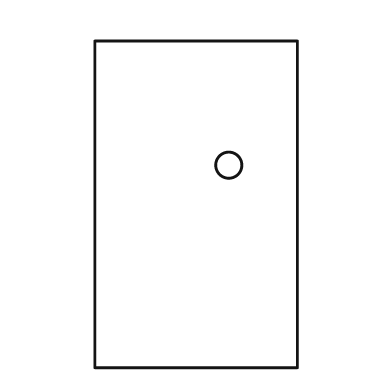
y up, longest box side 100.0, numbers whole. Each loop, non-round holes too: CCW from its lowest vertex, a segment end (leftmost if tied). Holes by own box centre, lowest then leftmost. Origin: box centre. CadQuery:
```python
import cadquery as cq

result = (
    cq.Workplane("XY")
    .moveTo(-31.0, -50.0)
    .lineTo(31.0, -50.0)
    .lineTo(31.0, 50.0)
    .lineTo(-31.0, 50.0)
    .close()
    .moveTo(10.0, 12.0)
    .circle(4.0)
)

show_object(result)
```